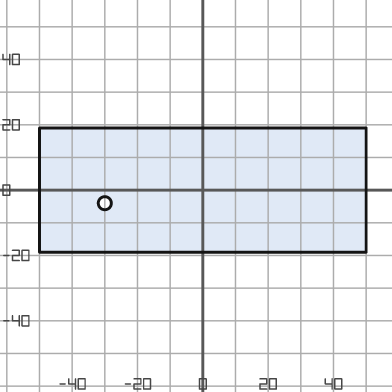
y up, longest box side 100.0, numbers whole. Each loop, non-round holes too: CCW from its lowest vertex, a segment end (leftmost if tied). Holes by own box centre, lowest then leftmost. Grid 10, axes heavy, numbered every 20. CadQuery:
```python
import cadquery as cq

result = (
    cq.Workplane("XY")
    .moveTo(-50.0, -19.0)
    .lineTo(50.0, -19.0)
    .lineTo(50.0, 19.0)
    .lineTo(-50.0, 19.0)
    .close()
    .moveTo(-30.0, -4.0)
    .circle(2.0)
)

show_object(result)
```